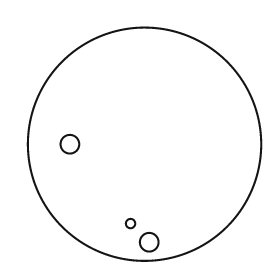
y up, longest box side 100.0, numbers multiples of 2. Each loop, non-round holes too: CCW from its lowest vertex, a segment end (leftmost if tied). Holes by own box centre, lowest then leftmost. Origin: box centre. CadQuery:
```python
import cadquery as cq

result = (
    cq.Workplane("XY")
    .moveTo(0.0, 0.0)
    .circle(50.0)
    .moveTo(2.0, -42.0)
    .circle(4.0)
    .moveTo(-6.0, -34.0)
    .circle(2.0)
    .moveTo(-32.0, 0.0)
    .circle(4.0)
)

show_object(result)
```